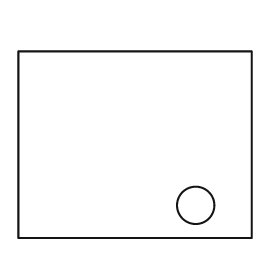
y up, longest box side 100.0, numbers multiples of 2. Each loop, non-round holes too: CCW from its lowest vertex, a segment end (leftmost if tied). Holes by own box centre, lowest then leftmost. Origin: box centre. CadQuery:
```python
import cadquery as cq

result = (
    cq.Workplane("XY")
    .moveTo(-50.0, -40.0)
    .lineTo(50.0, -40.0)
    .lineTo(50.0, 40.0)
    .lineTo(-50.0, 40.0)
    .close()
    .moveTo(26.0, -26.0)
    .circle(8.0)
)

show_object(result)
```